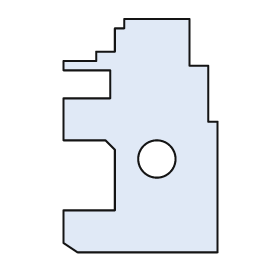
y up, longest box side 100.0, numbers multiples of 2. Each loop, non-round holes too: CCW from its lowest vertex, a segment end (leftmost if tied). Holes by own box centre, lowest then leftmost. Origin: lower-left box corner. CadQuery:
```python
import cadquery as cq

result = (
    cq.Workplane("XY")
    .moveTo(6.0, 0.0)
    .lineTo(66.0, 0.0)
    .lineTo(66.0, 56.0)
    .lineTo(62.0, 56.0)
    .lineTo(62.0, 80.0)
    .lineTo(54.0, 80.0)
    .lineTo(54.0, 100.0)
    .lineTo(26.0, 100.0)
    .lineTo(26.0, 96.0)
    .lineTo(22.0, 96.0)
    .lineTo(22.0, 86.0)
    .lineTo(14.0, 86.0)
    .lineTo(14.0, 82.0)
    .lineTo(0.0, 82.0)
    .lineTo(0.0, 78.0)
    .lineTo(20.0, 78.0)
    .lineTo(20.0, 66.0)
    .lineTo(0.0, 66.0)
    .lineTo(0.0, 48.0)
    .lineTo(18.0, 48.0)
    .lineTo(22.0, 44.0)
    .lineTo(22.0, 18.0)
    .lineTo(0.0, 18.0)
    .lineTo(0.0, 4.0)
    .close()
    .moveTo(40.0, 40.0)
    .circle(8.0)
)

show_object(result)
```